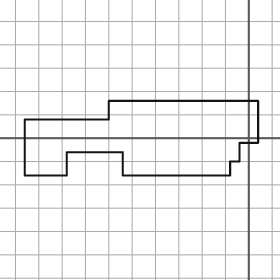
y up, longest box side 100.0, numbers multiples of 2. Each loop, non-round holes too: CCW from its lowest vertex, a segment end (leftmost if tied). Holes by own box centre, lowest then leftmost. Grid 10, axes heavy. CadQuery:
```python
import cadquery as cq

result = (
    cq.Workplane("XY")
    .moveTo(-96.0, -16.0)
    .lineTo(-78.0, -16.0)
    .lineTo(-78.0, -6.0)
    .lineTo(-54.0, -6.0)
    .lineTo(-54.0, -16.0)
    .lineTo(-8.0, -16.0)
    .lineTo(-8.0, -10.0)
    .lineTo(-4.0, -10.0)
    .lineTo(-4.0, -2.0)
    .lineTo(4.0, -2.0)
    .lineTo(4.0, 16.0)
    .lineTo(-60.0, 16.0)
    .lineTo(-60.0, 8.0)
    .lineTo(-96.0, 8.0)
    .close()
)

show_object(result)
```